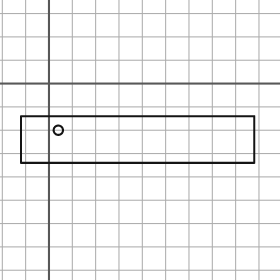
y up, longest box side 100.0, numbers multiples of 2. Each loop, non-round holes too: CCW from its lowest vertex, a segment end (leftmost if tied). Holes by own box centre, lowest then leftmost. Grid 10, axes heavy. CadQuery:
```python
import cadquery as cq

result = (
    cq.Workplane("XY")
    .moveTo(-12.0, -34.0)
    .lineTo(88.0, -34.0)
    .lineTo(88.0, -14.0)
    .lineTo(-12.0, -14.0)
    .close()
    .moveTo(4.0, -20.0)
    .circle(2.0)
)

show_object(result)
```